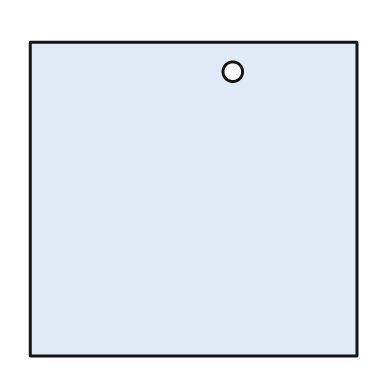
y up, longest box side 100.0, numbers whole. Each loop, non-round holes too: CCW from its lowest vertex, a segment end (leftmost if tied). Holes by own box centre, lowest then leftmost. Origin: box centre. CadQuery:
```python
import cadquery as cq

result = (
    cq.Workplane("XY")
    .moveTo(-50.0, -48.0)
    .lineTo(50.0, -48.0)
    .lineTo(50.0, 48.0)
    .lineTo(-50.0, 48.0)
    .close()
    .moveTo(12.0, 39.0)
    .circle(3.0)
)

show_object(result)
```